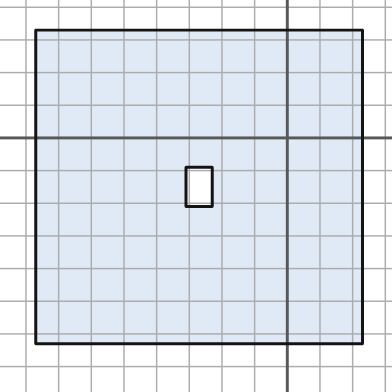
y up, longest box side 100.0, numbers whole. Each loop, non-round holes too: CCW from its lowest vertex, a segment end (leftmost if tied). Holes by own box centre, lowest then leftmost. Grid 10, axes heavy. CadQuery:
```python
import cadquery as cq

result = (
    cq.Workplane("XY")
    .moveTo(-77.0, -63.0)
    .lineTo(23.0, -63.0)
    .lineTo(23.0, 33.0)
    .lineTo(-77.0, 33.0)
    .close()
    .moveTo(-31.0, -21.0)
    .lineTo(-23.0, -21.0)
    .lineTo(-23.0, -9.0)
    .lineTo(-31.0, -9.0)
    .close()
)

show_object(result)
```